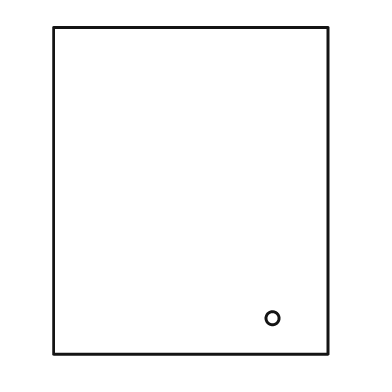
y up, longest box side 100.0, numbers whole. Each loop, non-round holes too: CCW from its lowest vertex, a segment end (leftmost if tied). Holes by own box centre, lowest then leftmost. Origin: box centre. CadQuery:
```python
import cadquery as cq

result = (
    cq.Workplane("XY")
    .moveTo(-42.0, -50.0)
    .lineTo(42.0, -50.0)
    .lineTo(42.0, 50.0)
    .lineTo(-42.0, 50.0)
    .close()
    .moveTo(25.0, -39.0)
    .circle(2.0)
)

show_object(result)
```